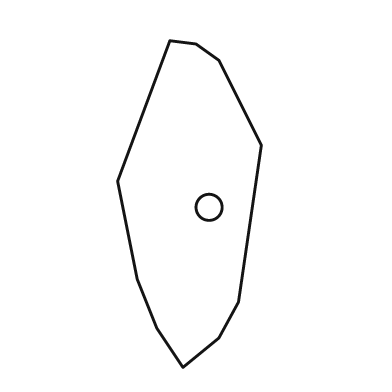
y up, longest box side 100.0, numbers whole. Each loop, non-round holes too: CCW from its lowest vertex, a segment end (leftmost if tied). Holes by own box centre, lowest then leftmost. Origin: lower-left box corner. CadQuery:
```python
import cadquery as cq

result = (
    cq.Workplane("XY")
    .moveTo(20.0, 0.0)
    .lineTo(31.0, 9.0)
    .lineTo(37.0, 20.0)
    .lineTo(44.0, 68.0)
    .lineTo(31.0, 94.0)
    .lineTo(24.0, 99.0)
    .lineTo(16.0, 100.0)
    .lineTo(0.0, 57.0)
    .lineTo(6.0, 27.0)
    .lineTo(12.0, 12.0)
    .close()
    .moveTo(28.0, 49.0)
    .circle(4.0)
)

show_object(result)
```